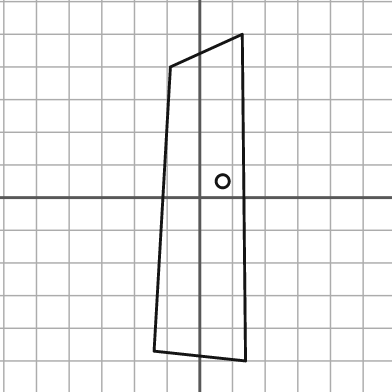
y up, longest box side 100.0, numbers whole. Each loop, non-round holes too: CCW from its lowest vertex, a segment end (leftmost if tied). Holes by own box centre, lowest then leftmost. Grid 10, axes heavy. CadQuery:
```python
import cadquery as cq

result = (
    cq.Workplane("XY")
    .moveTo(14.0, -50.0)
    .lineTo(13.0, 50.0)
    .lineTo(-9.0, 40.0)
    .lineTo(-14.0, -47.0)
    .close()
    .moveTo(7.0, 5.0)
    .circle(2.0)
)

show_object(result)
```